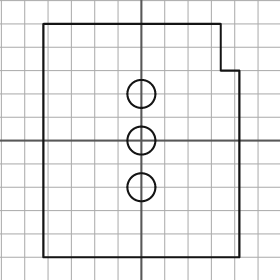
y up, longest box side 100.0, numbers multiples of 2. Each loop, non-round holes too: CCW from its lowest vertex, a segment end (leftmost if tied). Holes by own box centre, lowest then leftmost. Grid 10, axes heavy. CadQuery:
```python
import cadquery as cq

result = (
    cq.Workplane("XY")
    .moveTo(-42.0, -50.0)
    .lineTo(42.0, -50.0)
    .lineTo(42.0, 30.0)
    .lineTo(34.0, 30.0)
    .lineTo(34.0, 50.0)
    .lineTo(-42.0, 50.0)
    .close()
    .moveTo(0.0, -20.0)
    .circle(6.0)
    .moveTo(0.0, 0.0)
    .circle(6.0)
    .moveTo(0.0, 20.0)
    .circle(6.0)
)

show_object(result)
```